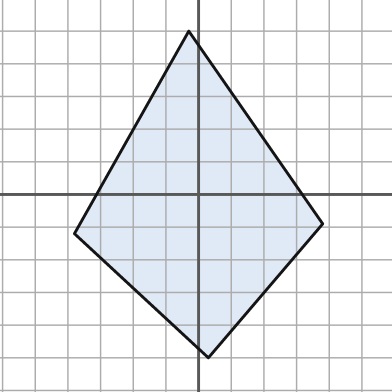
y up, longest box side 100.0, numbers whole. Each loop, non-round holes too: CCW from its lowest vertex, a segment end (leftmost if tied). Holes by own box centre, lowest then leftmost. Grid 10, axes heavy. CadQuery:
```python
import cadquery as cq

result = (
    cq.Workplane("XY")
    .moveTo(3.0, -50.0)
    .lineTo(38.0, -9.0)
    .lineTo(-3.0, 50.0)
    .lineTo(-38.0, -12.0)
    .close()
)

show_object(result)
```